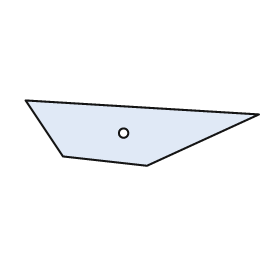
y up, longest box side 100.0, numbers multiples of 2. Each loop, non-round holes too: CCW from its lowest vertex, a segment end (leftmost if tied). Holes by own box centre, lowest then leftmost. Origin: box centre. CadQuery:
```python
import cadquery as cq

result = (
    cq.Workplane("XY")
    .moveTo(2.0, -14.0)
    .lineTo(50.0, 8.0)
    .lineTo(-50.0, 14.0)
    .lineTo(-34.0, -10.0)
    .close()
    .moveTo(-8.0, 0.0)
    .circle(2.0)
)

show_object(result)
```